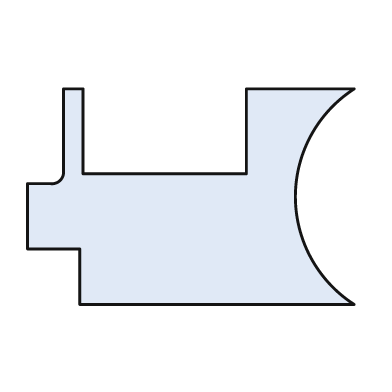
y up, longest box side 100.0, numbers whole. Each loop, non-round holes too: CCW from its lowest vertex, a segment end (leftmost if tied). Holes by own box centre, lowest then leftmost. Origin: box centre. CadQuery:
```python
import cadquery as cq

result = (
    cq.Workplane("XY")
    .moveTo(-34.0, -33.0)
    .lineTo(50.0, -33.0)
    .threePointArc((32.0, 0.0), (50.0, 33.0))
    .lineTo(17.0, 33.0)
    .lineTo(17.0, 7.0)
    .lineTo(-33.0, 7.0)
    .lineTo(-33.0, 33.0)
    .lineTo(-39.0, 33.0)
    .lineTo(-39.0, 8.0)
    .threePointArc((-40.0, 5.0), (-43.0, 4.0))
    .lineTo(-50.0, 4.0)
    .lineTo(-50.0, -16.0)
    .lineTo(-34.0, -16.0)
    .close()
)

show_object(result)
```